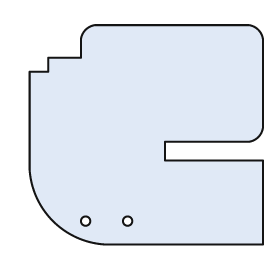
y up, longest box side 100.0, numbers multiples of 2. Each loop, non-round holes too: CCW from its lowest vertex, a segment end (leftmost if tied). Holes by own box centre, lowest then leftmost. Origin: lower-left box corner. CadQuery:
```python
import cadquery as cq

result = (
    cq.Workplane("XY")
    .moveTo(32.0, 0.0)
    .lineTo(100.0, 0.0)
    .lineTo(100.0, 36.0)
    .lineTo(58.0, 36.0)
    .lineTo(58.0, 44.0)
    .lineTo(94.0, 44.0)
    .threePointArc((98.0, 46.0), (100.0, 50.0))
    .lineTo(100.0, 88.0)
    .threePointArc((98.0, 92.0), (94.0, 94.0))
    .lineTo(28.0, 94.0)
    .threePointArc((24.0, 92.0), (22.0, 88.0))
    .lineTo(22.0, 80.0)
    .lineTo(8.0, 80.0)
    .lineTo(8.0, 74.0)
    .lineTo(0.0, 74.0)
    .lineTo(0.0, 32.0)
    .threePointArc((10.0, 10.0), (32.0, 0.0))
    .close()
    .moveTo(24.0, 10.0)
    .circle(2.0)
    .moveTo(42.0, 10.0)
    .circle(2.0)
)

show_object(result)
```